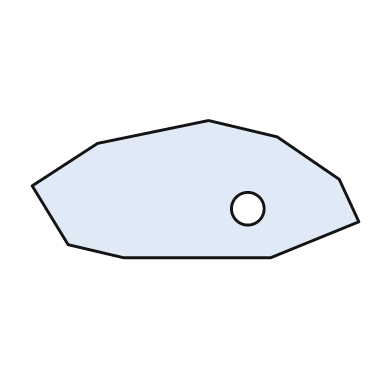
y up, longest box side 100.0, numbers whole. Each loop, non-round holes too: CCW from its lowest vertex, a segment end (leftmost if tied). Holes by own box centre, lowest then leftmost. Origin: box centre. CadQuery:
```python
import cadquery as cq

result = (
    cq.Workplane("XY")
    .moveTo(-22.0, -21.0)
    .lineTo(23.0, -21.0)
    .lineTo(50.0, -10.0)
    .lineTo(44.0, 3.0)
    .lineTo(25.0, 16.0)
    .lineTo(4.0, 21.0)
    .lineTo(-30.0, 14.0)
    .lineTo(-50.0, 1.0)
    .lineTo(-39.0, -17.0)
    .close()
    .moveTo(16.0, -6.0)
    .circle(5.0)
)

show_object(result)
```